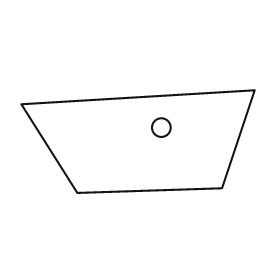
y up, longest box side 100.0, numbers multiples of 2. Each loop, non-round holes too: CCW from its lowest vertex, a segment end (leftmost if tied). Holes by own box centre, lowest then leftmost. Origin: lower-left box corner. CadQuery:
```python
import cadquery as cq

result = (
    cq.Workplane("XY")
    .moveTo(24.0, 0.0)
    .lineTo(86.0, 2.0)
    .lineTo(100.0, 44.0)
    .lineTo(0.0, 38.0)
    .close()
    .moveTo(60.0, 28.0)
    .circle(4.0)
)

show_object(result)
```